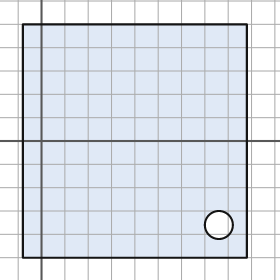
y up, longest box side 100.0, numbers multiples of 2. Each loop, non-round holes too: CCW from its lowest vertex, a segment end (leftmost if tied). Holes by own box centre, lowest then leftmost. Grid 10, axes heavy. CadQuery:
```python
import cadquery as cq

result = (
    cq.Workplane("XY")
    .moveTo(-8.0, -50.0)
    .lineTo(88.0, -50.0)
    .lineTo(88.0, 50.0)
    .lineTo(-8.0, 50.0)
    .close()
    .moveTo(76.0, -36.0)
    .circle(6.0)
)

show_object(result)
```